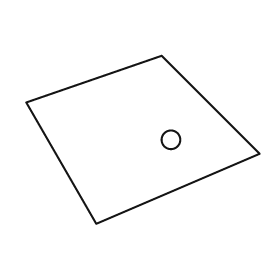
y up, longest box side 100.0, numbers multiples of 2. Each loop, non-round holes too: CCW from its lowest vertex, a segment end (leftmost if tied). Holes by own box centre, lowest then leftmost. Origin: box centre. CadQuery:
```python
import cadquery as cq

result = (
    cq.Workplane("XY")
    .moveTo(-20.0, -36.0)
    .lineTo(50.0, -6.0)
    .lineTo(8.0, 36.0)
    .lineTo(-50.0, 16.0)
    .close()
    .moveTo(12.0, 0.0)
    .circle(4.0)
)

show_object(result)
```